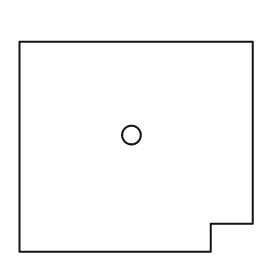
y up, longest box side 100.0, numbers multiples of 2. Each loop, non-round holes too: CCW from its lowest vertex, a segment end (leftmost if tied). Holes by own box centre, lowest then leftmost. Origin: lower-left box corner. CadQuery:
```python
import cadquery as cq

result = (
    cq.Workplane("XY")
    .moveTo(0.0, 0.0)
    .lineTo(82.0, 0.0)
    .lineTo(82.0, 12.0)
    .lineTo(100.0, 12.0)
    .lineTo(100.0, 90.0)
    .lineTo(0.0, 90.0)
    .close()
    .moveTo(48.0, 50.0)
    .circle(4.0)
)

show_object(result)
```